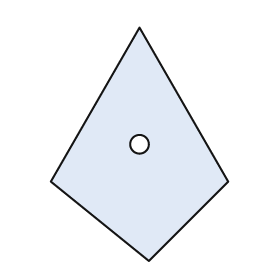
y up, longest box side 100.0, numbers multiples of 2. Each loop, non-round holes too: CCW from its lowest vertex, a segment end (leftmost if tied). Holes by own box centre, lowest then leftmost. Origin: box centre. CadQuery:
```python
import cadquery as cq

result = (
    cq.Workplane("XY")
    .moveTo(4.0, -50.0)
    .lineTo(38.0, -16.0)
    .lineTo(0.0, 50.0)
    .lineTo(-38.0, -16.0)
    .close()
    .moveTo(0.0, 0.0)
    .circle(4.0)
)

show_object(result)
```